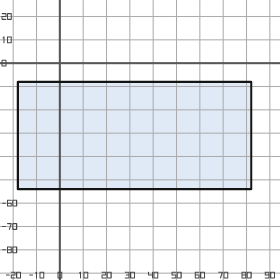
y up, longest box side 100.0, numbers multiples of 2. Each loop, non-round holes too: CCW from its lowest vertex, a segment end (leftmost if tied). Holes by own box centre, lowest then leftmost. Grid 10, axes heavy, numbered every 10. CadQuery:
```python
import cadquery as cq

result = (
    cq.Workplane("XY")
    .moveTo(-18.0, -54.0)
    .lineTo(82.0, -54.0)
    .lineTo(82.0, -8.0)
    .lineTo(-18.0, -8.0)
    .close()
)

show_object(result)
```